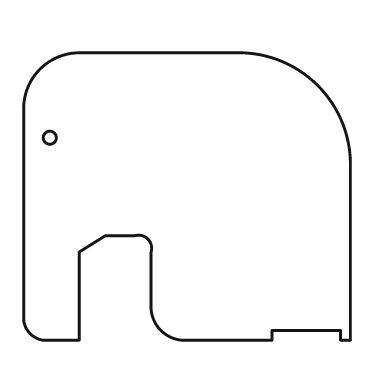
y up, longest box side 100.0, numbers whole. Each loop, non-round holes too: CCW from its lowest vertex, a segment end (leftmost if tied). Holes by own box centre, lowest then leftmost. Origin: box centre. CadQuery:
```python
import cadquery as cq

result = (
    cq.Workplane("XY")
    .moveTo(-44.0, -44.0)
    .lineTo(-33.0, -44.0)
    .lineTo(-33.0, -17.0)
    .lineTo(-25.0, -12.0)
    .lineTo(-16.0, -12.0)
    .threePointArc((-12.0, -13.0), (-11.0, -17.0))
    .lineTo(-11.0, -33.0)
    .threePointArc((-8.0, -41.0), (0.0, -44.0))
    .lineTo(26.0, -44.0)
    .lineTo(26.0, -41.0)
    .lineTo(47.0, -41.0)
    .lineTo(47.0, -44.0)
    .lineTo(50.0, -44.0)
    .lineTo(50.0, 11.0)
    .threePointArc((40.0, 34.0), (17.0, 44.0))
    .lineTo(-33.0, 44.0)
    .threePointArc((-45.0, 39.0), (-50.0, 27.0))
    .lineTo(-50.0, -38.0)
    .threePointArc((-48.0, -42.0), (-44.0, -44.0))
    .close()
    .moveTo(-42.0, 18.0)
    .circle(2.0)
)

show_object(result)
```